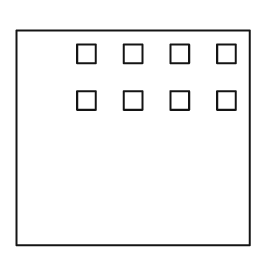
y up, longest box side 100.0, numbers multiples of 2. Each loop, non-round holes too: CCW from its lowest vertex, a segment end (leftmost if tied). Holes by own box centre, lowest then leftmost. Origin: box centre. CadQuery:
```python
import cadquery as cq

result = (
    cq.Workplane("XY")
    .moveTo(-50.0, -46.0)
    .lineTo(50.0, -46.0)
    .lineTo(50.0, 46.0)
    .lineTo(-50.0, 46.0)
    .close()
    .moveTo(-24.0, 12.0)
    .lineTo(-16.0, 12.0)
    .lineTo(-16.0, 20.0)
    .lineTo(-24.0, 20.0)
    .close()
    .moveTo(-4.0, 12.0)
    .lineTo(4.0, 12.0)
    .lineTo(4.0, 20.0)
    .lineTo(-4.0, 20.0)
    .close()
    .moveTo(16.0, 12.0)
    .lineTo(24.0, 12.0)
    .lineTo(24.0, 20.0)
    .lineTo(16.0, 20.0)
    .close()
    .moveTo(36.0, 12.0)
    .lineTo(44.0, 12.0)
    .lineTo(44.0, 20.0)
    .lineTo(36.0, 20.0)
    .close()
    .moveTo(-24.0, 32.0)
    .lineTo(-16.0, 32.0)
    .lineTo(-16.0, 40.0)
    .lineTo(-24.0, 40.0)
    .close()
    .moveTo(-4.0, 32.0)
    .lineTo(4.0, 32.0)
    .lineTo(4.0, 40.0)
    .lineTo(-4.0, 40.0)
    .close()
    .moveTo(16.0, 32.0)
    .lineTo(24.0, 32.0)
    .lineTo(24.0, 40.0)
    .lineTo(16.0, 40.0)
    .close()
    .moveTo(36.0, 32.0)
    .lineTo(44.0, 32.0)
    .lineTo(44.0, 40.0)
    .lineTo(36.0, 40.0)
    .close()
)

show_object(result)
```